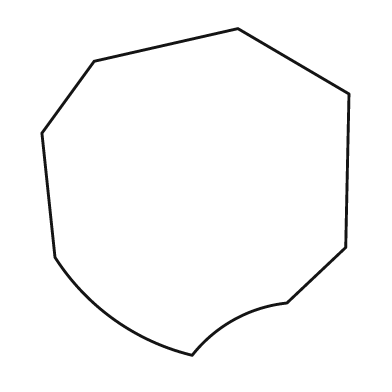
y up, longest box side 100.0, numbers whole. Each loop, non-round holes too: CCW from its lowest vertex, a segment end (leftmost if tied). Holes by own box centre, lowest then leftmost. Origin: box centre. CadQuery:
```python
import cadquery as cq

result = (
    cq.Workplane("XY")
    .moveTo(-1.0, -50.0)
    .threePointArc((12.0, -39.0), (28.0, -34.0))
    .lineTo(46.0, -17.0)
    .lineTo(47.0, 30.0)
    .lineTo(13.0, 50.0)
    .lineTo(-31.0, 40.0)
    .lineTo(-47.0, 18.0)
    .lineTo(-43.0, -20.0)
    .threePointArc((-25.0, -39.0), (-1.0, -50.0))
    .close()
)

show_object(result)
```